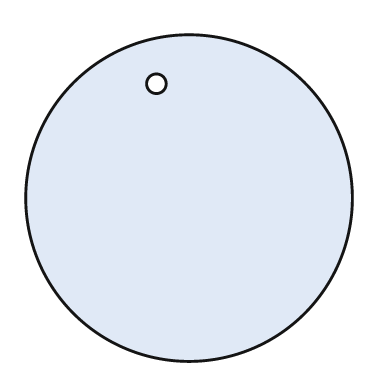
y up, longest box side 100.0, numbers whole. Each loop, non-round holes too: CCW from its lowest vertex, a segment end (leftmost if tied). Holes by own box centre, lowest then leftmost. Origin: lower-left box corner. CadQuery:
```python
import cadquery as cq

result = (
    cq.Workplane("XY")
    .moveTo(50.0, 50.0)
    .circle(50.0)
    .moveTo(40.0, 85.0)
    .circle(3.0)
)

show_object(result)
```